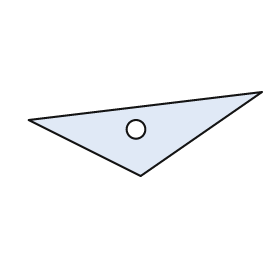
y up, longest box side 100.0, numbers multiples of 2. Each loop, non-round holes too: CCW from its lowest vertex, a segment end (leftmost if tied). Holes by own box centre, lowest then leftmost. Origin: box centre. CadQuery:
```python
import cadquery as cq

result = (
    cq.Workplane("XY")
    .moveTo(-2.0, -18.0)
    .lineTo(50.0, 18.0)
    .lineTo(-50.0, 6.0)
    .close()
    .moveTo(-4.0, 2.0)
    .circle(4.0)
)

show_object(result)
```